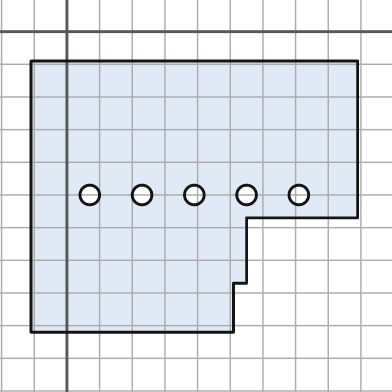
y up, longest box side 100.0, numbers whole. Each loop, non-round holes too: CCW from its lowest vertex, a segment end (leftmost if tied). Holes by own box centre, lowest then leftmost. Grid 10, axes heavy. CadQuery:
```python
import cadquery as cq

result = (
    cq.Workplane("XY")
    .moveTo(-11.0, -92.0)
    .lineTo(51.0, -92.0)
    .lineTo(51.0, -77.0)
    .lineTo(55.0, -77.0)
    .lineTo(55.0, -57.0)
    .lineTo(89.0, -57.0)
    .lineTo(89.0, -9.0)
    .lineTo(-11.0, -9.0)
    .close()
    .moveTo(7.0, -50.0)
    .circle(3.0)
    .moveTo(23.0, -50.0)
    .circle(3.0)
    .moveTo(39.0, -50.0)
    .circle(3.0)
    .moveTo(55.0, -50.0)
    .circle(3.0)
    .moveTo(71.0, -50.0)
    .circle(3.0)
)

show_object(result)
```